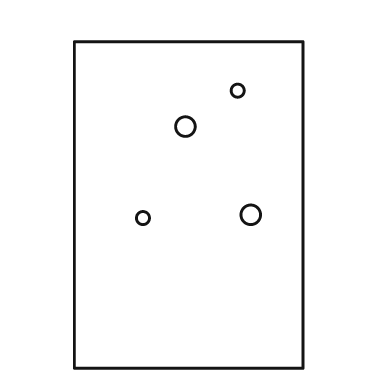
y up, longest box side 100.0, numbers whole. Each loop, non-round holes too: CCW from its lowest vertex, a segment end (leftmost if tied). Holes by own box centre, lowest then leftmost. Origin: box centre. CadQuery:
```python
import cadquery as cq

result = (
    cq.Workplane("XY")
    .moveTo(-35.0, -50.0)
    .lineTo(35.0, -50.0)
    .lineTo(35.0, 50.0)
    .lineTo(-35.0, 50.0)
    .close()
    .moveTo(-14.0, -4.0)
    .circle(2.0)
    .moveTo(19.0, -3.0)
    .circle(3.0)
    .moveTo(-1.0, 24.0)
    .circle(3.0)
    .moveTo(15.0, 35.0)
    .circle(2.0)
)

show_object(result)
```